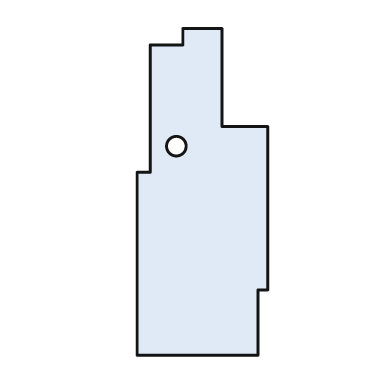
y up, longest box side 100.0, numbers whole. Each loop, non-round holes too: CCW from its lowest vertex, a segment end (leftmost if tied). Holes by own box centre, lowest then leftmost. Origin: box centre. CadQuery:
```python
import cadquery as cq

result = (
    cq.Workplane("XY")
    .moveTo(-20.0, -50.0)
    .lineTo(17.0, -50.0)
    .lineTo(17.0, -30.0)
    .lineTo(20.0, -30.0)
    .lineTo(20.0, 20.0)
    .lineTo(6.0, 20.0)
    .lineTo(6.0, 50.0)
    .lineTo(-6.0, 50.0)
    .lineTo(-6.0, 45.0)
    .lineTo(-16.0, 45.0)
    .lineTo(-16.0, 6.0)
    .lineTo(-20.0, 6.0)
    .close()
    .moveTo(-8.0, 14.0)
    .circle(3.0)
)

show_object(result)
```